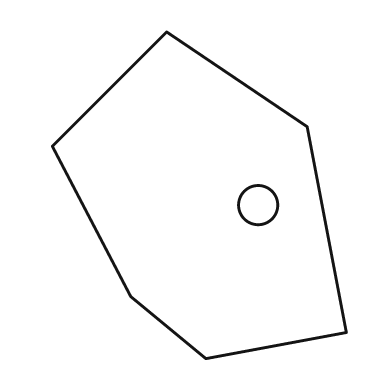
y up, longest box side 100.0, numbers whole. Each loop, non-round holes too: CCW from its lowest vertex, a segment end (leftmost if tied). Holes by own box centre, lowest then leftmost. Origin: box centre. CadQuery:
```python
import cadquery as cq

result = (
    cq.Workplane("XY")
    .moveTo(2.0, -50.0)
    .lineTo(45.0, -42.0)
    .lineTo(33.0, 21.0)
    .lineTo(-10.0, 50.0)
    .lineTo(-45.0, 15.0)
    .lineTo(-21.0, -31.0)
    .close()
    .moveTo(18.0, -3.0)
    .circle(6.0)
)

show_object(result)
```